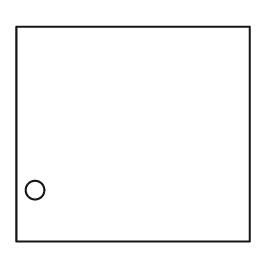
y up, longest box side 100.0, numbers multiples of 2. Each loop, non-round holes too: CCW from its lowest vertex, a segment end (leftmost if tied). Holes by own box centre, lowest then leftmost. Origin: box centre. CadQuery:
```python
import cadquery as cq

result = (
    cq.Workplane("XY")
    .moveTo(-50.0, -46.0)
    .lineTo(50.0, -46.0)
    .lineTo(50.0, 46.0)
    .lineTo(-50.0, 46.0)
    .close()
    .moveTo(-42.0, -24.0)
    .circle(4.0)
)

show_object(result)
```